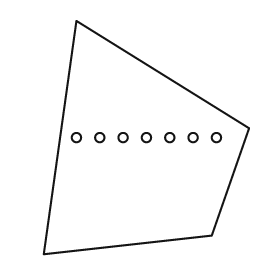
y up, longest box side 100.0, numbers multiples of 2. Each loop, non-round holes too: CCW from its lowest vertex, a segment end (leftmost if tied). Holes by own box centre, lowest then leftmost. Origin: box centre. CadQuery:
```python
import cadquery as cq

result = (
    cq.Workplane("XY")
    .moveTo(-44.0, -50.0)
    .lineTo(28.0, -42.0)
    .lineTo(44.0, 4.0)
    .lineTo(-30.0, 50.0)
    .close()
    .moveTo(-30.0, 0.0)
    .circle(2.0)
    .moveTo(-20.0, 0.0)
    .circle(2.0)
    .moveTo(-10.0, 0.0)
    .circle(2.0)
    .moveTo(0.0, 0.0)
    .circle(2.0)
    .moveTo(10.0, 0.0)
    .circle(2.0)
    .moveTo(20.0, 0.0)
    .circle(2.0)
    .moveTo(30.0, 0.0)
    .circle(2.0)
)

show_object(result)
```